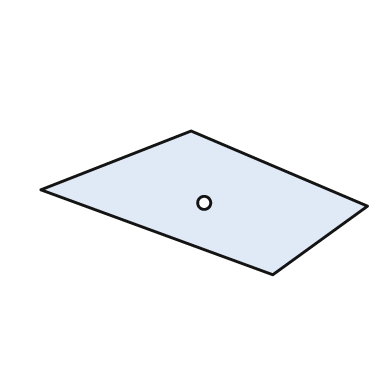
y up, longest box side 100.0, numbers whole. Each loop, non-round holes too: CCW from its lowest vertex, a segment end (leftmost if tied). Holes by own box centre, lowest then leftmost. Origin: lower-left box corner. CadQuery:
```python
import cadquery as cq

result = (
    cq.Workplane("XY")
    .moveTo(71.0, 0.0)
    .lineTo(100.0, 21.0)
    .lineTo(46.0, 44.0)
    .lineTo(0.0, 26.0)
    .close()
    .moveTo(50.0, 22.0)
    .circle(2.0)
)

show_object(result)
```